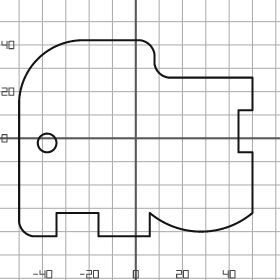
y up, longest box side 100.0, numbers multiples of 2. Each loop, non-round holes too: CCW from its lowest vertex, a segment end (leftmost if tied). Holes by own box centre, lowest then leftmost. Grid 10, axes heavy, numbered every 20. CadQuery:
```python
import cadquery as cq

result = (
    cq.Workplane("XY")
    .moveTo(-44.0, -42.0)
    .lineTo(-34.0, -42.0)
    .lineTo(-34.0, -32.0)
    .lineTo(-16.0, -32.0)
    .lineTo(-16.0, -42.0)
    .lineTo(6.0, -42.0)
    .lineTo(6.0, -32.0)
    .threePointArc((28.0, -40.0), (50.0, -32.0))
    .lineTo(50.0, -6.0)
    .lineTo(44.0, -6.0)
    .lineTo(44.0, 12.0)
    .lineTo(50.0, 12.0)
    .lineTo(50.0, 26.0)
    .lineTo(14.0, 26.0)
    .threePointArc((10.0, 28.0), (8.0, 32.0))
    .lineTo(8.0, 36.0)
    .threePointArc((6.0, 40.0), (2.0, 42.0))
    .lineTo(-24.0, 42.0)
    .threePointArc((-42.0, 34.0), (-50.0, 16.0))
    .lineTo(-50.0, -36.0)
    .threePointArc((-48.0, -40.0), (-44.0, -42.0))
    .close()
    .moveTo(-38.0, -2.0)
    .circle(4.0)
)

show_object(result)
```